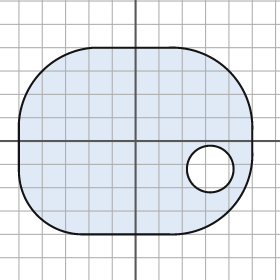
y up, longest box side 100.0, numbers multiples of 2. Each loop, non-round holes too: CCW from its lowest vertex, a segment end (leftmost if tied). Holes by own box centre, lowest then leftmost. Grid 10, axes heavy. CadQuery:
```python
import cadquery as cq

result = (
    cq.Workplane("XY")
    .moveTo(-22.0, -40.0)
    .lineTo(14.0, -40.0)
    .threePointArc((40.0, -30.0), (50.0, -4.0))
    .lineTo(50.0, 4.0)
    .threePointArc((40.0, 30.0), (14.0, 40.0))
    .lineTo(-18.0, 40.0)
    .threePointArc((-40.0, 30.0), (-50.0, 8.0))
    .lineTo(-50.0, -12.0)
    .threePointArc((-42.0, -32.0), (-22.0, -40.0))
    .close()
    .moveTo(32.0, -12.0)
    .circle(10.0)
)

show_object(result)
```